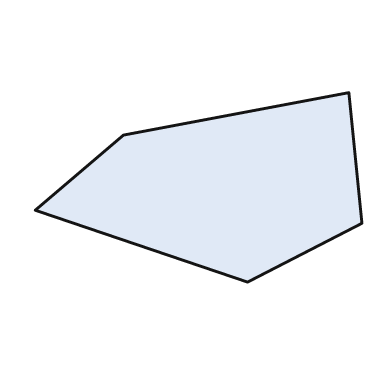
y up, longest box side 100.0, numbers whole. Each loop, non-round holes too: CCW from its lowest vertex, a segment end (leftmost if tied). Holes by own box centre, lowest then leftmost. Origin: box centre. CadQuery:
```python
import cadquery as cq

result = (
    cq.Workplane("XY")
    .moveTo(15.0, -29.0)
    .lineTo(50.0, -11.0)
    .lineTo(46.0, 29.0)
    .lineTo(-23.0, 16.0)
    .lineTo(-50.0, -7.0)
    .close()
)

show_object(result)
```